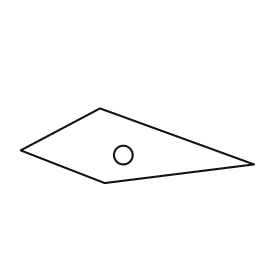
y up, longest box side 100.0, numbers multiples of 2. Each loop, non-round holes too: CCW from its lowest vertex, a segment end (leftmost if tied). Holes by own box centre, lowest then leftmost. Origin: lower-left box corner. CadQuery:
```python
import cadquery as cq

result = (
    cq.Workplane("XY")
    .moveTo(36.0, 0.0)
    .lineTo(100.0, 8.0)
    .lineTo(34.0, 32.0)
    .lineTo(0.0, 14.0)
    .close()
    .moveTo(44.0, 12.0)
    .circle(4.0)
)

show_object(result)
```